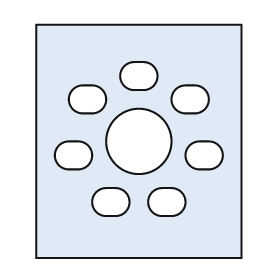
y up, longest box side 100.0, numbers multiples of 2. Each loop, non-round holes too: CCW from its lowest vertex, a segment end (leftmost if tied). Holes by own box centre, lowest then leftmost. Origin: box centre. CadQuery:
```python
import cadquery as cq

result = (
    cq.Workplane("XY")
    .moveTo(-44.0, -50.0)
    .lineTo(44.0, -50.0)
    .lineTo(44.0, 50.0)
    .lineTo(-44.0, 50.0)
    .close()
    .moveTo(-14.0, -32.0)
    .lineTo(-10.0, -32.0)
    .threePointArc((-4.0, -26.0), (-10.0, -20.0))
    .lineTo(-14.0, -20.0)
    .threePointArc((-20.0, -26.0), (-14.0, -32.0))
    .close()
    .moveTo(10.0, -32.0)
    .lineTo(14.0, -32.0)
    .threePointArc((20.0, -26.0), (14.0, -20.0))
    .lineTo(10.0, -20.0)
    .threePointArc((4.0, -26.0), (10.0, -32.0))
    .close()
    .moveTo(-30.0, -12.0)
    .lineTo(-26.0, -12.0)
    .threePointArc((-20.0, -6.0), (-26.0, 0.0))
    .lineTo(-30.0, 0.0)
    .threePointArc((-36.0, -6.0), (-30.0, -12.0))
    .close()
    .moveTo(26.0, -12.0)
    .lineTo(30.0, -12.0)
    .threePointArc((36.0, -6.0), (30.0, 0.0))
    .lineTo(26.0, 0.0)
    .threePointArc((20.0, -6.0), (26.0, -12.0))
    .close()
    .moveTo(0.0, 0.0)
    .circle(14.0)
    .moveTo(-24.0, 12.0)
    .lineTo(-20.0, 12.0)
    .threePointArc((-14.0, 18.0), (-20.0, 24.0))
    .lineTo(-24.0, 24.0)
    .threePointArc((-30.0, 18.0), (-24.0, 12.0))
    .close()
    .moveTo(20.0, 12.0)
    .lineTo(24.0, 12.0)
    .threePointArc((30.0, 18.0), (24.0, 24.0))
    .lineTo(20.0, 24.0)
    .threePointArc((14.0, 18.0), (20.0, 12.0))
    .close()
    .moveTo(-2.0, 22.0)
    .lineTo(2.0, 22.0)
    .threePointArc((8.0, 28.0), (2.0, 34.0))
    .lineTo(-2.0, 34.0)
    .threePointArc((-8.0, 28.0), (-2.0, 22.0))
    .close()
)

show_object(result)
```